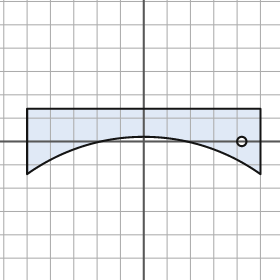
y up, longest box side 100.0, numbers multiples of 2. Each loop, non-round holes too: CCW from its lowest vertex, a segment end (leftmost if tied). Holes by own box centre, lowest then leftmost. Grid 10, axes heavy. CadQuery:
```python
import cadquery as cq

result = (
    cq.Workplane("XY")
    .moveTo(-50.0, -14.0)
    .threePointArc((0.0, 2.0), (50.0, -14.0))
    .lineTo(50.0, 14.0)
    .lineTo(-50.0, 14.0)
    .close()
    .moveTo(42.0, 0.0)
    .circle(2.0)
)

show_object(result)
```